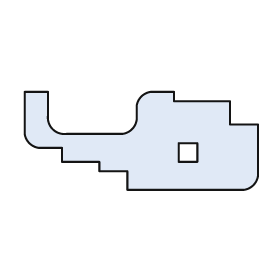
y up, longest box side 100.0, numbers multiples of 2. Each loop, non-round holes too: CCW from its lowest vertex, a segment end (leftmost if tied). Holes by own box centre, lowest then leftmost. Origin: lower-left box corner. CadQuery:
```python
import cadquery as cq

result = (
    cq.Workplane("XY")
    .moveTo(44.0, 0.0)
    .lineTo(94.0, 0.0)
    .threePointArc((98.0, 2.0), (100.0, 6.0))
    .lineTo(100.0, 28.0)
    .lineTo(88.0, 28.0)
    .lineTo(88.0, 38.0)
    .lineTo(64.0, 38.0)
    .lineTo(64.0, 42.0)
    .lineTo(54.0, 42.0)
    .threePointArc((50.0, 40.0), (48.0, 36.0))
    .lineTo(48.0, 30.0)
    .threePointArc((46.0, 26.0), (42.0, 24.0))
    .lineTo(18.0, 24.0)
    .threePointArc((12.0, 26.0), (10.0, 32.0))
    .lineTo(10.0, 42.0)
    .lineTo(0.0, 42.0)
    .lineTo(0.0, 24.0)
    .threePointArc((2.0, 20.0), (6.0, 18.0))
    .lineTo(16.0, 18.0)
    .lineTo(16.0, 12.0)
    .lineTo(32.0, 12.0)
    .lineTo(32.0, 8.0)
    .lineTo(44.0, 8.0)
    .close()
    .moveTo(66.0, 12.0)
    .lineTo(74.0, 12.0)
    .lineTo(74.0, 20.0)
    .lineTo(66.0, 20.0)
    .close()
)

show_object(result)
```